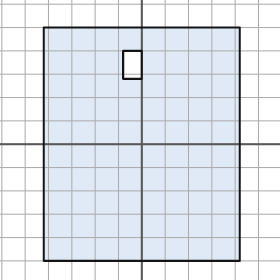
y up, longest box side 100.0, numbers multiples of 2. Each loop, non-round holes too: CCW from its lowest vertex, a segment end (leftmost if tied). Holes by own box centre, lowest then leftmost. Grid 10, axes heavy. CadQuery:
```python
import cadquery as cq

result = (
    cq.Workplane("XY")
    .moveTo(-42.0, -50.0)
    .lineTo(42.0, -50.0)
    .lineTo(42.0, 50.0)
    .lineTo(-42.0, 50.0)
    .close()
    .moveTo(-8.0, 28.0)
    .lineTo(0.0, 28.0)
    .lineTo(0.0, 40.0)
    .lineTo(-8.0, 40.0)
    .close()
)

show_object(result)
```